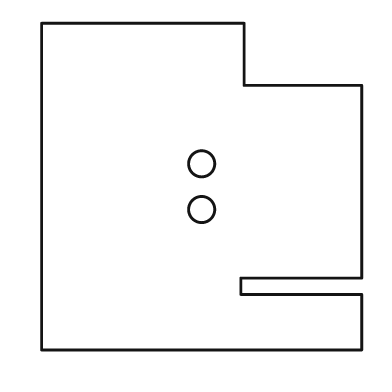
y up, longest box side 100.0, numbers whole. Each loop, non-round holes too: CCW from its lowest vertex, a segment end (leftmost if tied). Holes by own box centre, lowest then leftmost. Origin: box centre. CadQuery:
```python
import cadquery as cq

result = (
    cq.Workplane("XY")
    .moveTo(-49.0, -50.0)
    .lineTo(49.0, -50.0)
    .lineTo(49.0, -33.0)
    .lineTo(12.0, -33.0)
    .lineTo(12.0, -28.0)
    .lineTo(49.0, -28.0)
    .lineTo(49.0, 31.0)
    .lineTo(13.0, 31.0)
    .lineTo(13.0, 50.0)
    .lineTo(-49.0, 50.0)
    .close()
    .moveTo(0.0, -7.0)
    .circle(4.0)
    .moveTo(0.0, 7.0)
    .circle(4.0)
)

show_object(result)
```